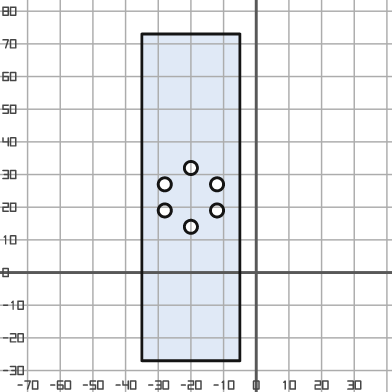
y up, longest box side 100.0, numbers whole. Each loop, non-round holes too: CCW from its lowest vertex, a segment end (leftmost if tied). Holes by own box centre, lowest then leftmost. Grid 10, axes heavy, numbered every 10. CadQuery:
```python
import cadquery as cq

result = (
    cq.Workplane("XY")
    .moveTo(-35.0, -27.0)
    .lineTo(-5.0, -27.0)
    .lineTo(-5.0, 73.0)
    .lineTo(-35.0, 73.0)
    .close()
    .moveTo(-20.0, 14.0)
    .circle(2.0)
    .moveTo(-28.0, 19.0)
    .circle(2.0)
    .moveTo(-12.0, 19.0)
    .circle(2.0)
    .moveTo(-28.0, 27.0)
    .circle(2.0)
    .moveTo(-12.0, 27.0)
    .circle(2.0)
    .moveTo(-20.0, 32.0)
    .circle(2.0)
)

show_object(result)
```